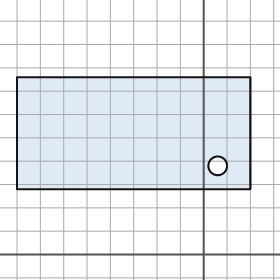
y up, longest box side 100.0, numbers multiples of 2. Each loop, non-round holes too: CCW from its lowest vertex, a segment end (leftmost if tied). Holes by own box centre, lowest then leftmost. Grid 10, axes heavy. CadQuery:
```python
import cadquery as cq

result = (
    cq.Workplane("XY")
    .moveTo(-80.0, 28.0)
    .lineTo(20.0, 28.0)
    .lineTo(20.0, 76.0)
    .lineTo(-80.0, 76.0)
    .close()
    .moveTo(6.0, 38.0)
    .circle(4.0)
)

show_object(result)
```